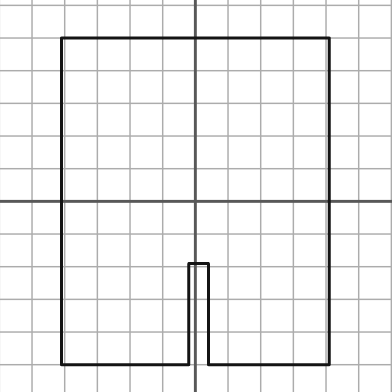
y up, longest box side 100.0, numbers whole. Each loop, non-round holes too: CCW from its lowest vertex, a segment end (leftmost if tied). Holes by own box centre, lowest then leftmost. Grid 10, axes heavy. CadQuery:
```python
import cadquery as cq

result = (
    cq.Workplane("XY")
    .moveTo(-41.0, -50.0)
    .lineTo(-2.0, -50.0)
    .lineTo(-2.0, -19.0)
    .lineTo(4.0, -19.0)
    .lineTo(4.0, -50.0)
    .lineTo(41.0, -50.0)
    .lineTo(41.0, 50.0)
    .lineTo(-41.0, 50.0)
    .close()
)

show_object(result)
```